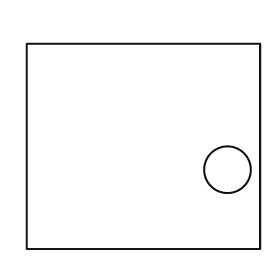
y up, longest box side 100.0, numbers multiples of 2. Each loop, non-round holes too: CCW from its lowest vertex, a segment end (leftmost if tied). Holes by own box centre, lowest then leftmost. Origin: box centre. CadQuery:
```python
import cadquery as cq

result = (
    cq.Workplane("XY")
    .moveTo(-50.0, -44.0)
    .lineTo(50.0, -44.0)
    .lineTo(50.0, 44.0)
    .lineTo(-50.0, 44.0)
    .close()
    .moveTo(36.0, -10.0)
    .circle(10.0)
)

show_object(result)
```